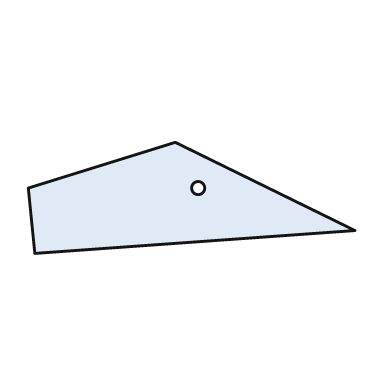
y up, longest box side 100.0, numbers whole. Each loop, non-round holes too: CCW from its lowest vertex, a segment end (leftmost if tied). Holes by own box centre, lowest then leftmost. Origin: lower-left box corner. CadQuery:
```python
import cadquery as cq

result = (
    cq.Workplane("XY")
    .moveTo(2.0, 0.0)
    .lineTo(100.0, 7.0)
    .lineTo(45.0, 34.0)
    .lineTo(0.0, 20.0)
    .close()
    .moveTo(52.0, 20.0)
    .circle(2.0)
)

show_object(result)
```